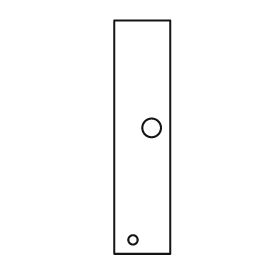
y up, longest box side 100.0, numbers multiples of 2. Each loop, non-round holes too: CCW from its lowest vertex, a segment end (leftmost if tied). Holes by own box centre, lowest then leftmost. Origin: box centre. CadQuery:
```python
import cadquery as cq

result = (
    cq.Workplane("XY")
    .moveTo(-12.0, -50.0)
    .lineTo(12.0, -50.0)
    .lineTo(12.0, 50.0)
    .lineTo(-12.0, 50.0)
    .close()
    .moveTo(-4.0, -44.0)
    .circle(2.0)
    .moveTo(4.0, 4.0)
    .circle(4.0)
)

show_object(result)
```